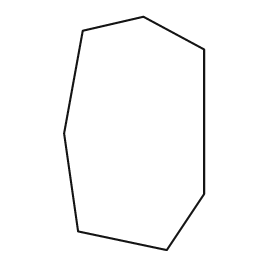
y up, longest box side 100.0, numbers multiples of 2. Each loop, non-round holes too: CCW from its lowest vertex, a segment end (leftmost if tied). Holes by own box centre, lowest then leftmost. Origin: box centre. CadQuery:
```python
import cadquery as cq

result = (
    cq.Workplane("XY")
    .moveTo(14.0, -50.0)
    .lineTo(30.0, -26.0)
    .lineTo(30.0, 36.0)
    .lineTo(4.0, 50.0)
    .lineTo(-22.0, 44.0)
    .lineTo(-30.0, 0.0)
    .lineTo(-24.0, -42.0)
    .close()
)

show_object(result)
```